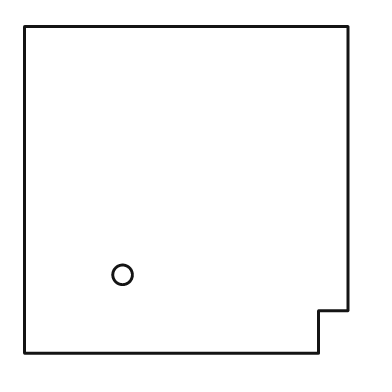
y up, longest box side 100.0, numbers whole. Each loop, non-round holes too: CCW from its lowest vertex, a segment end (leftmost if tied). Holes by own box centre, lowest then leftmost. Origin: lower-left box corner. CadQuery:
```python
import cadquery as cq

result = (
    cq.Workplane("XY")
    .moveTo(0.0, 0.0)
    .lineTo(90.0, 0.0)
    .lineTo(90.0, 13.0)
    .lineTo(99.0, 13.0)
    .lineTo(99.0, 100.0)
    .lineTo(0.0, 100.0)
    .close()
    .moveTo(30.0, 24.0)
    .circle(3.0)
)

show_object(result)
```